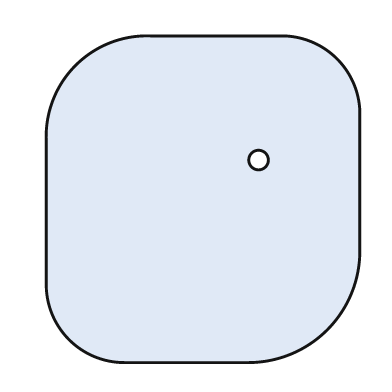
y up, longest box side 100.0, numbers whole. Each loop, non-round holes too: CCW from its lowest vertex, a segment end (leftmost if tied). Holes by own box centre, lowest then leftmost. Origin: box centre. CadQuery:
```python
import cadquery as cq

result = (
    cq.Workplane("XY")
    .moveTo(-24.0, -50.0)
    .lineTo(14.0, -50.0)
    .threePointArc((38.0, -40.0), (48.0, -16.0))
    .lineTo(48.0, 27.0)
    .threePointArc((41.0, 43.0), (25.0, 50.0))
    .lineTo(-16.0, 50.0)
    .threePointArc((-39.0, 41.0), (-48.0, 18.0))
    .lineTo(-48.0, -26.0)
    .threePointArc((-41.0, -43.0), (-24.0, -50.0))
    .close()
    .moveTo(17.0, 12.0)
    .circle(3.0)
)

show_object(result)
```